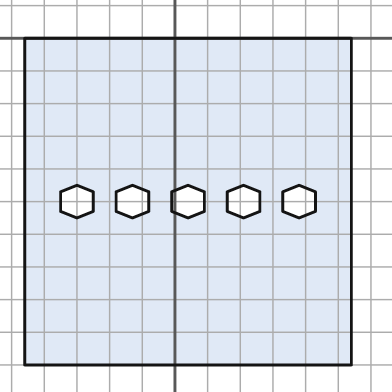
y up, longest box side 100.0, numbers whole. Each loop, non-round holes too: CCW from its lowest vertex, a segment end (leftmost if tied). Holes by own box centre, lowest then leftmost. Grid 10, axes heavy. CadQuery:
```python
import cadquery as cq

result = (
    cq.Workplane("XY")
    .moveTo(-46.0, -100.0)
    .lineTo(54.0, -100.0)
    .lineTo(54.0, 0.0)
    .lineTo(-46.0, 0.0)
    .close()
    .moveTo(-30.0, -55.0)
    .lineTo(-25.0, -53.0)
    .lineTo(-25.0, -47.0)
    .lineTo(-30.0, -45.0)
    .lineTo(-35.0, -47.0)
    .lineTo(-35.0, -53.0)
    .close()
    .moveTo(-13.0, -55.0)
    .lineTo(-8.0, -53.0)
    .lineTo(-8.0, -47.0)
    .lineTo(-13.0, -45.0)
    .lineTo(-18.0, -47.0)
    .lineTo(-18.0, -53.0)
    .close()
    .moveTo(4.0, -55.0)
    .lineTo(9.0, -53.0)
    .lineTo(9.0, -47.0)
    .lineTo(4.0, -45.0)
    .lineTo(-1.0, -47.0)
    .lineTo(-1.0, -53.0)
    .close()
    .moveTo(21.0, -55.0)
    .lineTo(26.0, -53.0)
    .lineTo(26.0, -47.0)
    .lineTo(21.0, -45.0)
    .lineTo(16.0, -47.0)
    .lineTo(16.0, -53.0)
    .close()
    .moveTo(38.0, -55.0)
    .lineTo(43.0, -53.0)
    .lineTo(43.0, -47.0)
    .lineTo(38.0, -45.0)
    .lineTo(33.0, -47.0)
    .lineTo(33.0, -53.0)
    .close()
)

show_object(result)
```